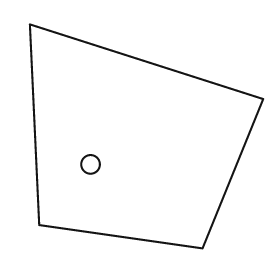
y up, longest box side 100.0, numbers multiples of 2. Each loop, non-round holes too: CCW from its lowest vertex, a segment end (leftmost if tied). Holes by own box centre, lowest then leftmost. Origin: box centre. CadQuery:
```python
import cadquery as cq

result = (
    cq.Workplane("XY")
    .moveTo(24.0, -48.0)
    .lineTo(50.0, 16.0)
    .lineTo(-50.0, 48.0)
    .lineTo(-46.0, -38.0)
    .close()
    .moveTo(-24.0, -12.0)
    .circle(4.0)
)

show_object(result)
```